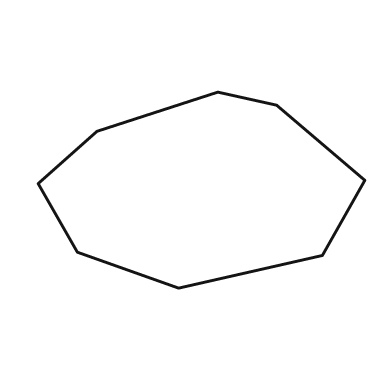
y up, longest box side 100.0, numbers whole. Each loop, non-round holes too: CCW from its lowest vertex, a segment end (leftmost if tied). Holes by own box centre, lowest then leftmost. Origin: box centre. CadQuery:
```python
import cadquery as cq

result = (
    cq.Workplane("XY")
    .moveTo(-7.0, -30.0)
    .lineTo(37.0, -20.0)
    .lineTo(50.0, 3.0)
    .lineTo(23.0, 26.0)
    .lineTo(5.0, 30.0)
    .lineTo(-32.0, 18.0)
    .lineTo(-50.0, 2.0)
    .lineTo(-38.0, -19.0)
    .close()
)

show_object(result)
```